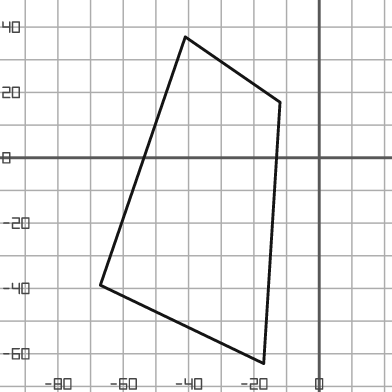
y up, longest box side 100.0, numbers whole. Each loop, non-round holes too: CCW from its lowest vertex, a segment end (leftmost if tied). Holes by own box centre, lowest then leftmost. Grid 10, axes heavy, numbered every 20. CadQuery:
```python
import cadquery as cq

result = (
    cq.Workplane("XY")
    .moveTo(-17.0, -63.0)
    .lineTo(-12.0, 17.0)
    .lineTo(-41.0, 37.0)
    .lineTo(-67.0, -39.0)
    .close()
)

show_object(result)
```